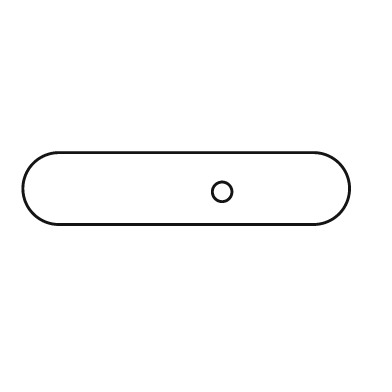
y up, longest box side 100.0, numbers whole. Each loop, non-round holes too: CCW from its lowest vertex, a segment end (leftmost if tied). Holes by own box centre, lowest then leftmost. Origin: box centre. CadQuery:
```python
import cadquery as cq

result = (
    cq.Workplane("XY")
    .moveTo(-39.0, -11.0)
    .lineTo(39.0, -11.0)
    .threePointArc((50.0, 0.0), (39.0, 11.0))
    .lineTo(-39.0, 11.0)
    .threePointArc((-50.0, 0.0), (-39.0, -11.0))
    .close()
    .moveTo(11.0, -1.0)
    .circle(3.0)
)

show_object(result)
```